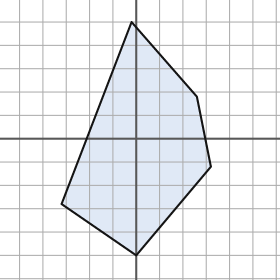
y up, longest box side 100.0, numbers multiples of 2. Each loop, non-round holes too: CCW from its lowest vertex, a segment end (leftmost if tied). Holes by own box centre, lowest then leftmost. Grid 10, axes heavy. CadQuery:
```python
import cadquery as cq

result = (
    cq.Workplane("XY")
    .moveTo(0.0, -50.0)
    .lineTo(32.0, -12.0)
    .lineTo(26.0, 18.0)
    .lineTo(-2.0, 50.0)
    .lineTo(-32.0, -28.0)
    .close()
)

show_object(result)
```